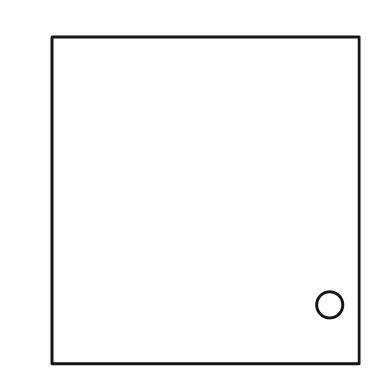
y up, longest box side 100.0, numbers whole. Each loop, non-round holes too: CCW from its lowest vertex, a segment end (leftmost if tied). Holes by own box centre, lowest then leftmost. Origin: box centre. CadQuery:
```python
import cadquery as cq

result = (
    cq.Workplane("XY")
    .moveTo(-47.0, -50.0)
    .lineTo(47.0, -50.0)
    .lineTo(47.0, 50.0)
    .lineTo(-47.0, 50.0)
    .close()
    .moveTo(38.0, -32.0)
    .circle(4.0)
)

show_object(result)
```